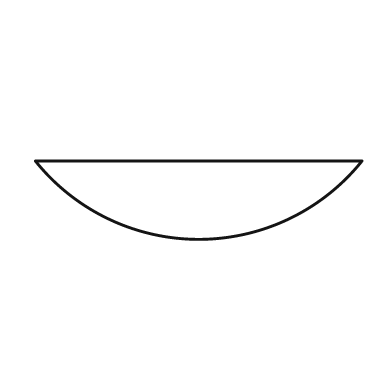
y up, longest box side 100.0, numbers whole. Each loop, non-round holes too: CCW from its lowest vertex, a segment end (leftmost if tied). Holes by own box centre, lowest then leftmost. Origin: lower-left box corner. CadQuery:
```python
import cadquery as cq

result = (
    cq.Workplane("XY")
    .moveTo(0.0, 24.0)
    .threePointArc((50.0, 0.0), (100.0, 24.0))
    .close()
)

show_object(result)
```